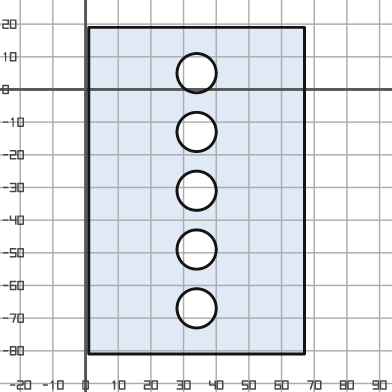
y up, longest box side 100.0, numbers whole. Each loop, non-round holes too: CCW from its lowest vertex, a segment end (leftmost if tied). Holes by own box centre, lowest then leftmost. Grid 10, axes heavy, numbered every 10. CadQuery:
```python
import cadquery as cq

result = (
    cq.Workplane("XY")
    .moveTo(1.0, -81.0)
    .lineTo(67.0, -81.0)
    .lineTo(67.0, 19.0)
    .lineTo(1.0, 19.0)
    .close()
    .moveTo(34.0, -67.0)
    .circle(6.0)
    .moveTo(34.0, -49.0)
    .circle(6.0)
    .moveTo(34.0, -31.0)
    .circle(6.0)
    .moveTo(34.0, -13.0)
    .circle(6.0)
    .moveTo(34.0, 5.0)
    .circle(6.0)
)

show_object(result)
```